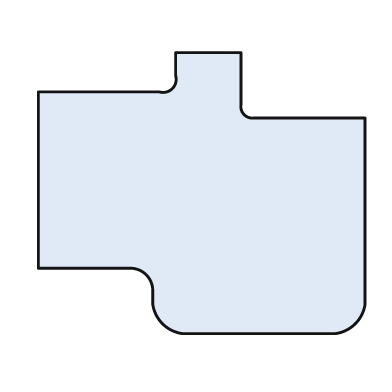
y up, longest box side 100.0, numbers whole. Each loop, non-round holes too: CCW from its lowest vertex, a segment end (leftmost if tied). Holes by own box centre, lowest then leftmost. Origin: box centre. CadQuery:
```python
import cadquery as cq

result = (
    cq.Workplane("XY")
    .moveTo(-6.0, -43.0)
    .lineTo(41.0, -43.0)
    .threePointArc((47.0, -40.0), (50.0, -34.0))
    .lineTo(50.0, 23.0)
    .lineTo(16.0, 23.0)
    .threePointArc((13.0, 24.0), (12.0, 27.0))
    .lineTo(12.0, 43.0)
    .lineTo(-8.0, 43.0)
    .lineTo(-8.0, 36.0)
    .threePointArc((-9.0, 32.0), (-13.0, 31.0))
    .lineTo(-50.0, 31.0)
    .lineTo(-50.0, -23.0)
    .lineTo(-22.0, -23.0)
    .threePointArc((-17.0, -25.0), (-15.0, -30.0))
    .lineTo(-15.0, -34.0)
    .threePointArc((-12.0, -40.0), (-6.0, -43.0))
    .close()
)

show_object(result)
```